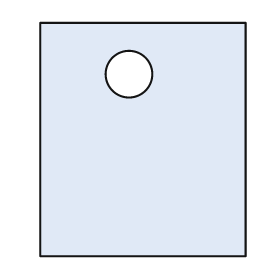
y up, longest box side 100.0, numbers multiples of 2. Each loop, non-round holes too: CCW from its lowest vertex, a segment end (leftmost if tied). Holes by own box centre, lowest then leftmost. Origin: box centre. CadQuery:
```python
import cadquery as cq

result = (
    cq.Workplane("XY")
    .moveTo(-44.0, -50.0)
    .lineTo(44.0, -50.0)
    .lineTo(44.0, 50.0)
    .lineTo(-44.0, 50.0)
    .close()
    .moveTo(-6.0, 28.0)
    .circle(10.0)
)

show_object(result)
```